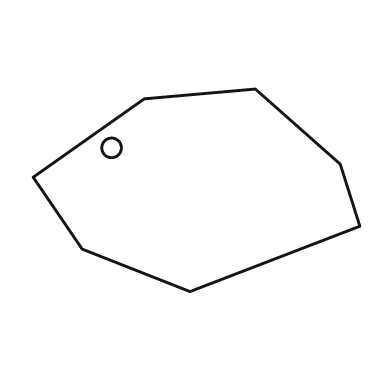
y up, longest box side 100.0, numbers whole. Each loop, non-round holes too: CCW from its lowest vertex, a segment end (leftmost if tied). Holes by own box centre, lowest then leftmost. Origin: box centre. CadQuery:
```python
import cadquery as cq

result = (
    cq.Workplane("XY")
    .moveTo(-2.0, -31.0)
    .lineTo(50.0, -11.0)
    .lineTo(44.0, 8.0)
    .lineTo(18.0, 31.0)
    .lineTo(-16.0, 28.0)
    .lineTo(-50.0, 4.0)
    .lineTo(-35.0, -18.0)
    .close()
    .moveTo(-26.0, 13.0)
    .circle(3.0)
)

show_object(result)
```